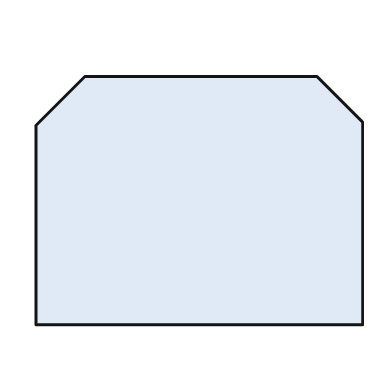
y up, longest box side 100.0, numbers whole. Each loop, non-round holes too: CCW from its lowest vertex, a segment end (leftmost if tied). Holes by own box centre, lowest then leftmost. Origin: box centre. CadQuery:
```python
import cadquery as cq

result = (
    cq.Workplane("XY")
    .moveTo(-50.0, -38.0)
    .lineTo(50.0, -38.0)
    .lineTo(50.0, 24.0)
    .lineTo(36.0, 38.0)
    .lineTo(-35.0, 38.0)
    .lineTo(-50.0, 23.0)
    .close()
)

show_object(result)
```